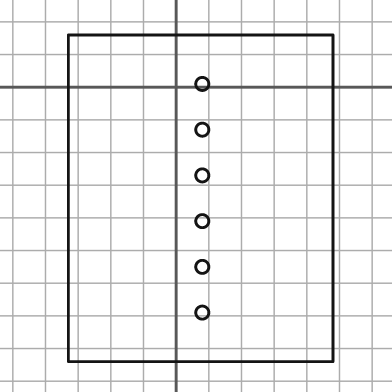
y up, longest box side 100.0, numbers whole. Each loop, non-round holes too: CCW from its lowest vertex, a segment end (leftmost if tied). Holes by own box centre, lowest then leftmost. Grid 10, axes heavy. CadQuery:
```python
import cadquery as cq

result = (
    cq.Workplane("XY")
    .moveTo(-33.0, -84.0)
    .lineTo(48.0, -84.0)
    .lineTo(48.0, 16.0)
    .lineTo(-33.0, 16.0)
    .close()
    .moveTo(8.0, -69.0)
    .circle(2.0)
    .moveTo(8.0, -55.0)
    .circle(2.0)
    .moveTo(8.0, -41.0)
    .circle(2.0)
    .moveTo(8.0, -27.0)
    .circle(2.0)
    .moveTo(8.0, -13.0)
    .circle(2.0)
    .moveTo(8.0, 1.0)
    .circle(2.0)
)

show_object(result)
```